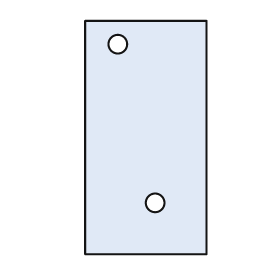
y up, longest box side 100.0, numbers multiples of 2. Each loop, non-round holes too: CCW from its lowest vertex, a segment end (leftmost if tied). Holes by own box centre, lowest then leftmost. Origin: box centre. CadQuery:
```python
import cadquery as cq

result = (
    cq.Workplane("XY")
    .moveTo(-26.0, -50.0)
    .lineTo(26.0, -50.0)
    .lineTo(26.0, 50.0)
    .lineTo(-26.0, 50.0)
    .close()
    .moveTo(4.0, -28.0)
    .circle(4.0)
    .moveTo(-12.0, 40.0)
    .circle(4.0)
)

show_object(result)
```